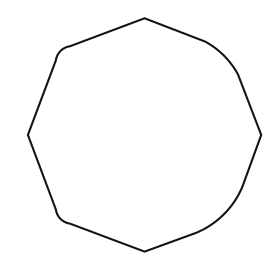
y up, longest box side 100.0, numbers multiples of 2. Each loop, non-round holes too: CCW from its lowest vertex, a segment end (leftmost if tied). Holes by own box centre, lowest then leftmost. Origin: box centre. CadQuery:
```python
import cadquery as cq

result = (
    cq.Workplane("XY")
    .moveTo(0.0, -50.0)
    .lineTo(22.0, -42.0)
    .threePointArc((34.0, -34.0), (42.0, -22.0))
    .lineTo(50.0, 0.0)
    .lineTo(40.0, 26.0)
    .threePointArc((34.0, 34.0), (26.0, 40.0))
    .lineTo(0.0, 50.0)
    .lineTo(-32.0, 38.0)
    .threePointArc((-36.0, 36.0), (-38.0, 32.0))
    .lineTo(-50.0, 0.0)
    .lineTo(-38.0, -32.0)
    .threePointArc((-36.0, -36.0), (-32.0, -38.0))
    .close()
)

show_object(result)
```